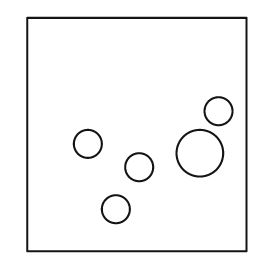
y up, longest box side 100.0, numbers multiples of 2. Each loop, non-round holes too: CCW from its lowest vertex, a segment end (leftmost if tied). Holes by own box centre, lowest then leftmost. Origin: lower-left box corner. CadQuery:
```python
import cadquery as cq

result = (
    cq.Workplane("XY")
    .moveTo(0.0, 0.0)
    .lineTo(94.0, 0.0)
    .lineTo(94.0, 100.0)
    .lineTo(0.0, 100.0)
    .close()
    .moveTo(38.0, 18.0)
    .circle(6.0)
    .moveTo(48.0, 36.0)
    .circle(6.0)
    .moveTo(74.0, 42.0)
    .circle(10.0)
    .moveTo(26.0, 46.0)
    .circle(6.0)
    .moveTo(82.0, 60.0)
    .circle(6.0)
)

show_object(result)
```